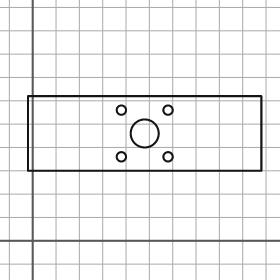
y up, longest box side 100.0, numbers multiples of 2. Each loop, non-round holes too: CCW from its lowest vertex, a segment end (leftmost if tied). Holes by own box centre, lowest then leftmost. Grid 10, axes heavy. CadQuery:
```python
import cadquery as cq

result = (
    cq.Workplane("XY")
    .moveTo(-2.0, 30.0)
    .lineTo(98.0, 30.0)
    .lineTo(98.0, 62.0)
    .lineTo(-2.0, 62.0)
    .close()
    .moveTo(38.0, 36.0)
    .circle(2.0)
    .moveTo(58.0, 36.0)
    .circle(2.0)
    .moveTo(48.0, 46.0)
    .circle(6.0)
    .moveTo(38.0, 56.0)
    .circle(2.0)
    .moveTo(58.0, 56.0)
    .circle(2.0)
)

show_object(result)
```